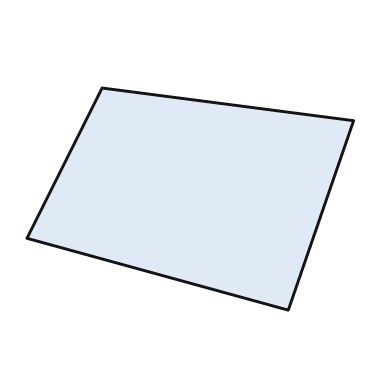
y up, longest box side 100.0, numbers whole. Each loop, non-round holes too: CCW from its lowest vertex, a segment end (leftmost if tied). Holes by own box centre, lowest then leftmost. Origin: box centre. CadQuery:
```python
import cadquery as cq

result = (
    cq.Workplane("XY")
    .moveTo(30.0, -34.0)
    .lineTo(50.0, 24.0)
    .lineTo(-27.0, 34.0)
    .lineTo(-50.0, -12.0)
    .close()
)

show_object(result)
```